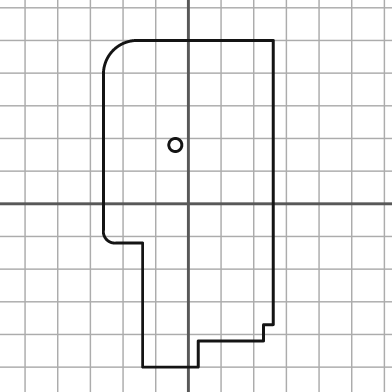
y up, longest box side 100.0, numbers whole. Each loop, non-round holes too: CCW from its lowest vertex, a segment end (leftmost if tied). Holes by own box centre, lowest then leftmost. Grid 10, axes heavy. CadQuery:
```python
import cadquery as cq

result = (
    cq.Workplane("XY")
    .moveTo(-14.0, -50.0)
    .lineTo(3.0, -50.0)
    .lineTo(3.0, -42.0)
    .lineTo(23.0, -42.0)
    .lineTo(23.0, -37.0)
    .lineTo(26.0, -37.0)
    .lineTo(26.0, 50.0)
    .lineTo(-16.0, 50.0)
    .threePointArc((-23.0, 47.0), (-26.0, 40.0))
    .lineTo(-26.0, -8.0)
    .threePointArc((-25.0, -11.0), (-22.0, -12.0))
    .lineTo(-14.0, -12.0)
    .close()
    .moveTo(-4.0, 18.0)
    .circle(2.0)
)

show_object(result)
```